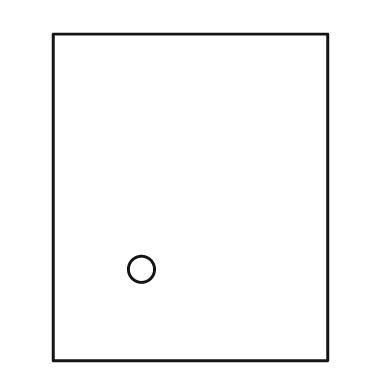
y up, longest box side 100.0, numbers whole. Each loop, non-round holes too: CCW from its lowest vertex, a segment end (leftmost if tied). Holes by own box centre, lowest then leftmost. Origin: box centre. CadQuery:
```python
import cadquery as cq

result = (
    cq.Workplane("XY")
    .moveTo(-42.0, -50.0)
    .lineTo(42.0, -50.0)
    .lineTo(42.0, 50.0)
    .lineTo(-42.0, 50.0)
    .close()
    .moveTo(-15.0, -22.0)
    .circle(4.0)
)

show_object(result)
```